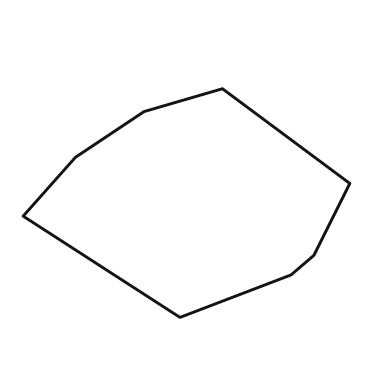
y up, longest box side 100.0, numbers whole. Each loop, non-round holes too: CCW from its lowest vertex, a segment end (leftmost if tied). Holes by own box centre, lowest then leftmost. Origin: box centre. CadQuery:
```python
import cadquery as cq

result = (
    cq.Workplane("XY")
    .moveTo(-2.0, -35.0)
    .lineTo(32.0, -22.0)
    .lineTo(39.0, -16.0)
    .lineTo(50.0, 6.0)
    .lineTo(11.0, 35.0)
    .lineTo(-13.0, 28.0)
    .lineTo(-34.0, 14.0)
    .lineTo(-50.0, -4.0)
    .close()
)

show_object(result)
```